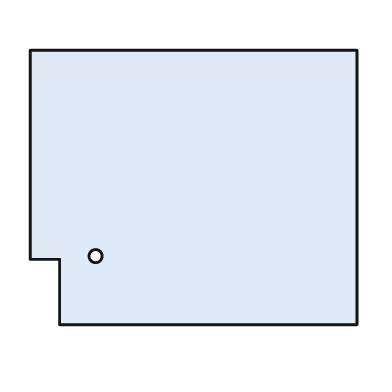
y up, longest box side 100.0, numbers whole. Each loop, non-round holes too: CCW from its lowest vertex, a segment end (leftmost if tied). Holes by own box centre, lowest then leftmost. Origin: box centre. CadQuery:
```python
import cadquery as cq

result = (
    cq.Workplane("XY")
    .moveTo(-41.0, -42.0)
    .lineTo(50.0, -42.0)
    .lineTo(50.0, 42.0)
    .lineTo(-50.0, 42.0)
    .lineTo(-50.0, -22.0)
    .lineTo(-41.0, -22.0)
    .close()
    .moveTo(-30.0, -21.0)
    .circle(2.0)
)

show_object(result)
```